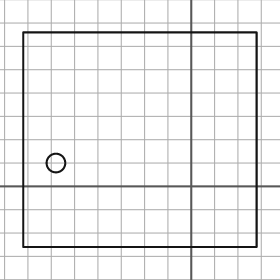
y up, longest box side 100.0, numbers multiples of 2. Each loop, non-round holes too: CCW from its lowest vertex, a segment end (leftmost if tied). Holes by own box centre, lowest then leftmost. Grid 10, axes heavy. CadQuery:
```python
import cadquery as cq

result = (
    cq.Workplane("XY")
    .moveTo(-72.0, -26.0)
    .lineTo(28.0, -26.0)
    .lineTo(28.0, 66.0)
    .lineTo(-72.0, 66.0)
    .close()
    .moveTo(-58.0, 10.0)
    .circle(4.0)
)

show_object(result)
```